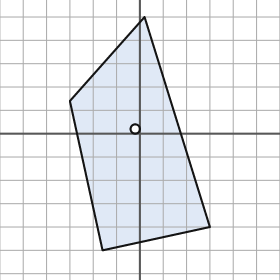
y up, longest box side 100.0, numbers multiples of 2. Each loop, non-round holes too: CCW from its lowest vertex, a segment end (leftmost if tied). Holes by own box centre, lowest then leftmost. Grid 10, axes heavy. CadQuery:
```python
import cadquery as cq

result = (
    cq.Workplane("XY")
    .moveTo(-16.0, -50.0)
    .lineTo(30.0, -40.0)
    .lineTo(2.0, 50.0)
    .lineTo(-30.0, 14.0)
    .close()
    .moveTo(-2.0, 2.0)
    .circle(2.0)
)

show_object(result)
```